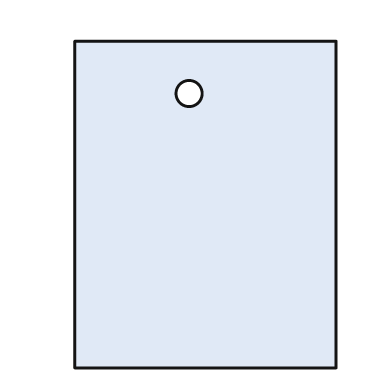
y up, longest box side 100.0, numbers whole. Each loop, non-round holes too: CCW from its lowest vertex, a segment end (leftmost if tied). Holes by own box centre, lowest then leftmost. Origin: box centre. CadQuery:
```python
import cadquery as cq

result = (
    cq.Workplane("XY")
    .moveTo(-40.0, -50.0)
    .lineTo(40.0, -50.0)
    .lineTo(40.0, 50.0)
    .lineTo(-40.0, 50.0)
    .close()
    .moveTo(-5.0, 34.0)
    .circle(4.0)
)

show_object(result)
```